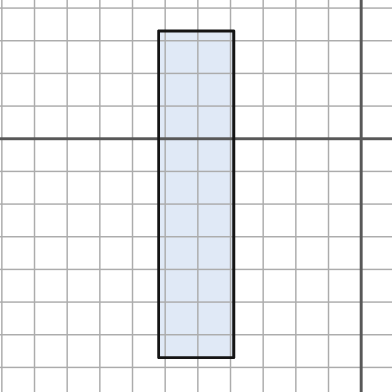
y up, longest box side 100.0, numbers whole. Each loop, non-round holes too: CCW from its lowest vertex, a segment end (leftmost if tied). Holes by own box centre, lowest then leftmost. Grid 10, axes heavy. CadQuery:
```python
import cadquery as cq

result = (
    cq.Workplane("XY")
    .moveTo(-62.0, -67.0)
    .lineTo(-39.0, -67.0)
    .lineTo(-39.0, 33.0)
    .lineTo(-62.0, 33.0)
    .close()
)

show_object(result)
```